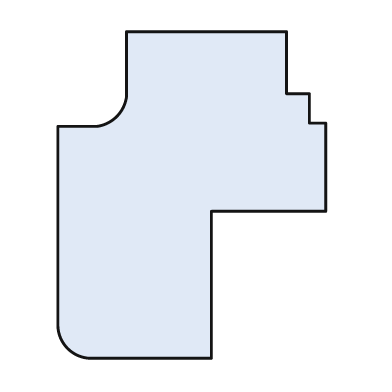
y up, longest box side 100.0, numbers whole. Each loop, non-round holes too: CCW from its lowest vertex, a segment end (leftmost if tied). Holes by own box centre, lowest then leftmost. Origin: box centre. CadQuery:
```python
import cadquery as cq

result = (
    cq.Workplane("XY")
    .moveTo(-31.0, -50.0)
    .lineTo(6.0, -50.0)
    .lineTo(6.0, -5.0)
    .lineTo(41.0, -5.0)
    .lineTo(41.0, 22.0)
    .lineTo(36.0, 22.0)
    .lineTo(36.0, 31.0)
    .lineTo(29.0, 31.0)
    .lineTo(29.0, 50.0)
    .lineTo(-20.0, 50.0)
    .lineTo(-20.0, 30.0)
    .threePointArc((-23.0, 24.0), (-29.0, 21.0))
    .lineTo(-41.0, 21.0)
    .lineTo(-41.0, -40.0)
    .threePointArc((-38.0, -47.0), (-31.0, -50.0))
    .close()
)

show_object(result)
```